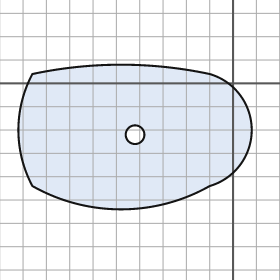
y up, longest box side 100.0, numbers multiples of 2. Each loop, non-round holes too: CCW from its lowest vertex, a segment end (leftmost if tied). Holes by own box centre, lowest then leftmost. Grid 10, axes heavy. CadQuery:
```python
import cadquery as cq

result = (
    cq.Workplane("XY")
    .moveTo(-86.0, -44.0)
    .threePointArc((-48.0, -54.0), (-10.0, -44.0))
    .threePointArc((8.0, -20.0), (-10.0, 4.0))
    .threePointArc((-48.0, 8.0), (-86.0, 4.0))
    .threePointArc((-92.0, -20.0), (-86.0, -44.0))
    .close()
    .moveTo(-42.0, -22.0)
    .circle(4.0)
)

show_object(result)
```